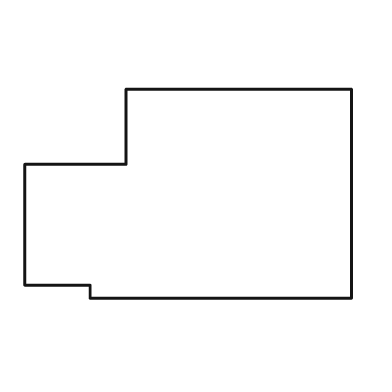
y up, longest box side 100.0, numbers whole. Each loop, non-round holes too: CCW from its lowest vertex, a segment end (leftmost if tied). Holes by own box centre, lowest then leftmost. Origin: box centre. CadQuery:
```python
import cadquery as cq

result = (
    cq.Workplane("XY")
    .moveTo(-30.0, -32.0)
    .lineTo(50.0, -32.0)
    .lineTo(50.0, 32.0)
    .lineTo(-19.0, 32.0)
    .lineTo(-19.0, 9.0)
    .lineTo(-50.0, 9.0)
    .lineTo(-50.0, -28.0)
    .lineTo(-30.0, -28.0)
    .close()
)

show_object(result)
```